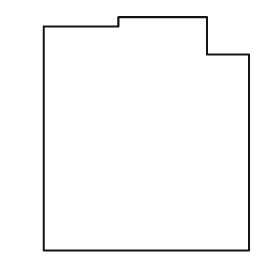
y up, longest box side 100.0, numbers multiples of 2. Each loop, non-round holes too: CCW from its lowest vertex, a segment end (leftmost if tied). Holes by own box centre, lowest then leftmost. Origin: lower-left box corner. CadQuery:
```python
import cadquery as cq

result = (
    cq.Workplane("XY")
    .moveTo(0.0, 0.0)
    .lineTo(88.0, 0.0)
    .lineTo(88.0, 84.0)
    .lineTo(70.0, 84.0)
    .lineTo(70.0, 100.0)
    .lineTo(32.0, 100.0)
    .lineTo(32.0, 96.0)
    .lineTo(0.0, 96.0)
    .close()
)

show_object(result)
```